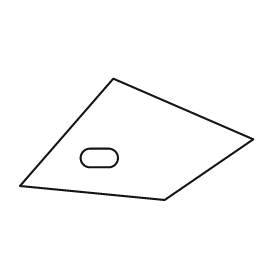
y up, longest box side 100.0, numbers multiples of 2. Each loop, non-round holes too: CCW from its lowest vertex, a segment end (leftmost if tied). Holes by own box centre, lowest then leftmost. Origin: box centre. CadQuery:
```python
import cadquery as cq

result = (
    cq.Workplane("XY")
    .moveTo(12.0, -26.0)
    .lineTo(50.0, 0.0)
    .lineTo(-10.0, 26.0)
    .lineTo(-50.0, -20.0)
    .close()
    .moveTo(-20.0, -12.0)
    .lineTo(-12.0, -12.0)
    .threePointArc((-8.0, -8.0), (-12.0, -4.0))
    .lineTo(-20.0, -4.0)
    .threePointArc((-24.0, -8.0), (-20.0, -12.0))
    .close()
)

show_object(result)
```